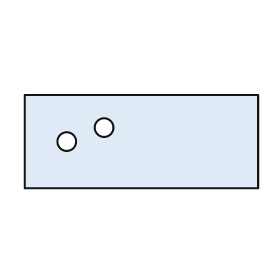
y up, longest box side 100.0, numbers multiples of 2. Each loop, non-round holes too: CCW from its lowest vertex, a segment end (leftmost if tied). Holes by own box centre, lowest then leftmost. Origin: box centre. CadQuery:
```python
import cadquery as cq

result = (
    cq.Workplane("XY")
    .moveTo(-50.0, -20.0)
    .lineTo(50.0, -20.0)
    .lineTo(50.0, 20.0)
    .lineTo(-50.0, 20.0)
    .close()
    .moveTo(-32.0, 0.0)
    .circle(4.0)
    .moveTo(-16.0, 6.0)
    .circle(4.0)
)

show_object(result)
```